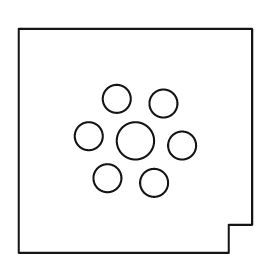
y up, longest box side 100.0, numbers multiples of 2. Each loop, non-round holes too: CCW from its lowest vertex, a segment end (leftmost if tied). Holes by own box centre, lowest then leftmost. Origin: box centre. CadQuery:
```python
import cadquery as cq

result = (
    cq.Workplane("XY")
    .moveTo(-50.0, -48.0)
    .lineTo(40.0, -48.0)
    .lineTo(40.0, -36.0)
    .lineTo(50.0, -36.0)
    .lineTo(50.0, 48.0)
    .lineTo(-50.0, 48.0)
    .close()
    .moveTo(8.0, -18.0)
    .circle(6.0)
    .moveTo(-12.0, -16.0)
    .circle(6.0)
    .moveTo(20.0, -2.0)
    .circle(6.0)
    .moveTo(0.0, 0.0)
    .circle(8.0)
    .moveTo(-20.0, 2.0)
    .circle(6.0)
    .moveTo(12.0, 16.0)
    .circle(6.0)
    .moveTo(-8.0, 18.0)
    .circle(6.0)
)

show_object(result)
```